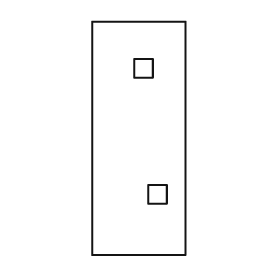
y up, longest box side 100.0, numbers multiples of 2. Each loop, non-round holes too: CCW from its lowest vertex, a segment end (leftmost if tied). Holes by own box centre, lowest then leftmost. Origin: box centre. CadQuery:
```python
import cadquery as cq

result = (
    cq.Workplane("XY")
    .moveTo(-20.0, -50.0)
    .lineTo(20.0, -50.0)
    .lineTo(20.0, 50.0)
    .lineTo(-20.0, 50.0)
    .close()
    .moveTo(4.0, -28.0)
    .lineTo(12.0, -28.0)
    .lineTo(12.0, -20.0)
    .lineTo(4.0, -20.0)
    .close()
    .moveTo(-2.0, 26.0)
    .lineTo(6.0, 26.0)
    .lineTo(6.0, 34.0)
    .lineTo(-2.0, 34.0)
    .close()
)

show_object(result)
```